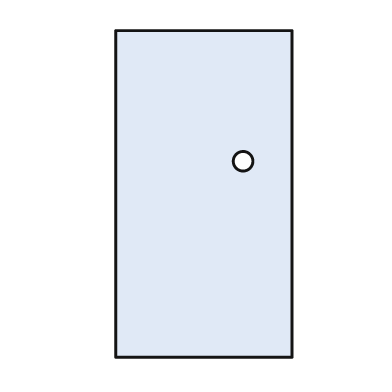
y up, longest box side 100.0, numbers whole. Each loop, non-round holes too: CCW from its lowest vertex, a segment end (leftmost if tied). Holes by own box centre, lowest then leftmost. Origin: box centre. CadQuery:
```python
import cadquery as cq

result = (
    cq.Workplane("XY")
    .moveTo(-27.0, -50.0)
    .lineTo(27.0, -50.0)
    .lineTo(27.0, 50.0)
    .lineTo(-27.0, 50.0)
    .close()
    .moveTo(12.0, 10.0)
    .circle(3.0)
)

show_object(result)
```